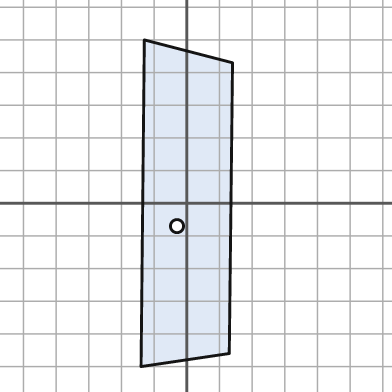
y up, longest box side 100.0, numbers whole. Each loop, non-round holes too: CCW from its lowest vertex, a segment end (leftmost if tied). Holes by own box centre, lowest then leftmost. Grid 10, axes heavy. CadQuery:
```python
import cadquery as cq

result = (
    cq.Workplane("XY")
    .moveTo(-14.0, -50.0)
    .lineTo(13.0, -46.0)
    .lineTo(14.0, 43.0)
    .lineTo(-13.0, 50.0)
    .close()
    .moveTo(-3.0, -7.0)
    .circle(2.0)
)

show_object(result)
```